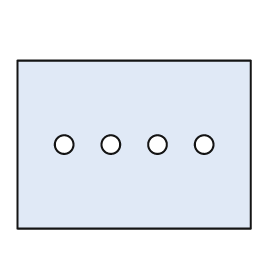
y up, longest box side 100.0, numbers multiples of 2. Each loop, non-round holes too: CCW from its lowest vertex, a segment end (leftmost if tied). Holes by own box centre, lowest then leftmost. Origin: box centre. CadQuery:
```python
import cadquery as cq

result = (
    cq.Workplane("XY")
    .moveTo(-50.0, -36.0)
    .lineTo(50.0, -36.0)
    .lineTo(50.0, 36.0)
    .lineTo(-50.0, 36.0)
    .close()
    .moveTo(-30.0, 0.0)
    .circle(4.0)
    .moveTo(-10.0, 0.0)
    .circle(4.0)
    .moveTo(10.0, 0.0)
    .circle(4.0)
    .moveTo(30.0, 0.0)
    .circle(4.0)
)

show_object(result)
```